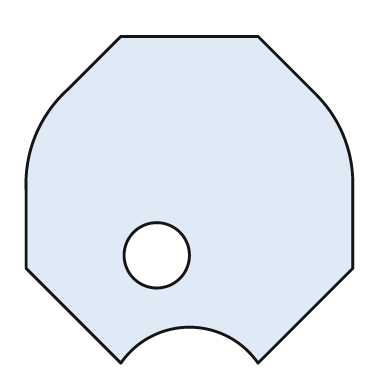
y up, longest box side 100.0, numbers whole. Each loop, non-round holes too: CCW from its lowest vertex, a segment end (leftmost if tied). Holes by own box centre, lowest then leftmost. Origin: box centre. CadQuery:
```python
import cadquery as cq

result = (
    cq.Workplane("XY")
    .moveTo(-21.0, -50.0)
    .threePointArc((0.0, -39.0), (21.0, -50.0))
    .lineTo(50.0, -21.0)
    .lineTo(50.0, 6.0)
    .threePointArc((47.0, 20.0), (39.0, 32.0))
    .lineTo(21.0, 50.0)
    .lineTo(-21.0, 50.0)
    .lineTo(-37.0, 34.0)
    .threePointArc((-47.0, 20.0), (-50.0, 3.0))
    .lineTo(-50.0, -21.0)
    .close()
    .moveTo(-10.0, -17.0)
    .circle(10.0)
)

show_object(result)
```